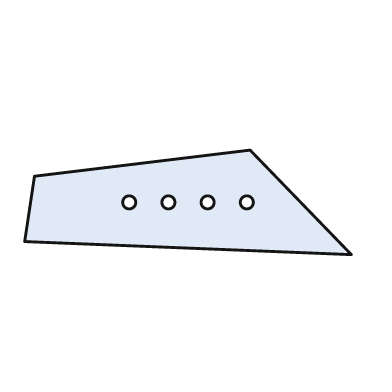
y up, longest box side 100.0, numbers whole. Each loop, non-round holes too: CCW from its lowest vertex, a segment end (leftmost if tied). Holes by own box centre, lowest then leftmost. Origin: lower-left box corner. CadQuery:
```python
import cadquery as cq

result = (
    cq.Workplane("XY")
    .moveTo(100.0, 0.0)
    .lineTo(69.0, 32.0)
    .lineTo(3.0, 24.0)
    .lineTo(0.0, 4.0)
    .close()
    .moveTo(32.0, 16.0)
    .circle(2.0)
    .moveTo(44.0, 16.0)
    .circle(2.0)
    .moveTo(56.0, 16.0)
    .circle(2.0)
    .moveTo(68.0, 16.0)
    .circle(2.0)
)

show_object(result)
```